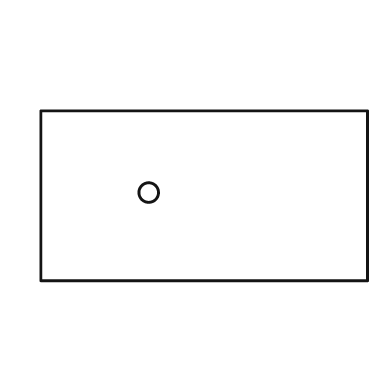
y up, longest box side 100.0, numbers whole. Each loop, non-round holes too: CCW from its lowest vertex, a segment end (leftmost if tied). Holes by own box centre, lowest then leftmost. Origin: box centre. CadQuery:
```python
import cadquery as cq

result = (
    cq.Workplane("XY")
    .moveTo(-50.0, -26.0)
    .lineTo(50.0, -26.0)
    .lineTo(50.0, 26.0)
    .lineTo(-50.0, 26.0)
    .close()
    .moveTo(-17.0, 1.0)
    .circle(3.0)
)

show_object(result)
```